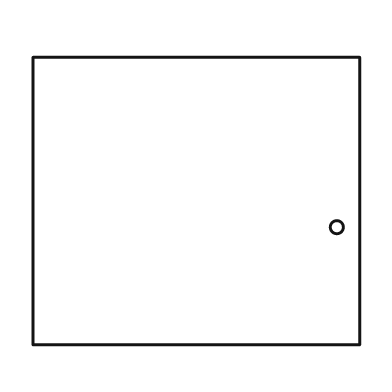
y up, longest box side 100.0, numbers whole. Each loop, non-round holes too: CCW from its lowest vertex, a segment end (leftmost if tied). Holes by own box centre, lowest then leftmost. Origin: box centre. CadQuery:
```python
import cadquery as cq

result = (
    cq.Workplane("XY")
    .moveTo(-50.0, -44.0)
    .lineTo(50.0, -44.0)
    .lineTo(50.0, 44.0)
    .lineTo(-50.0, 44.0)
    .close()
    .moveTo(43.0, -8.0)
    .circle(2.0)
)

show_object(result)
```